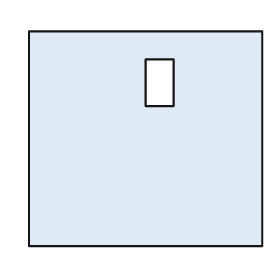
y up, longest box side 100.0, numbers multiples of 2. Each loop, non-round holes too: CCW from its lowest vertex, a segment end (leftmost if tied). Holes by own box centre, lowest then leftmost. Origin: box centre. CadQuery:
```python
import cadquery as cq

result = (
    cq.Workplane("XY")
    .moveTo(-50.0, -46.0)
    .lineTo(50.0, -46.0)
    .lineTo(50.0, 46.0)
    .lineTo(-50.0, 46.0)
    .close()
    .moveTo(0.0, 14.0)
    .lineTo(12.0, 14.0)
    .lineTo(12.0, 34.0)
    .lineTo(0.0, 34.0)
    .close()
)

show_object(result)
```